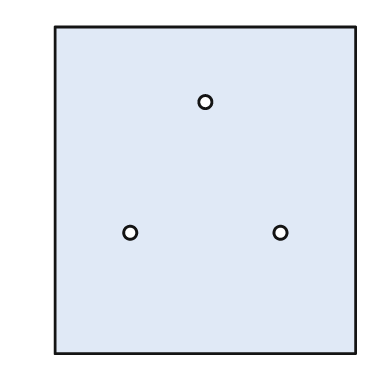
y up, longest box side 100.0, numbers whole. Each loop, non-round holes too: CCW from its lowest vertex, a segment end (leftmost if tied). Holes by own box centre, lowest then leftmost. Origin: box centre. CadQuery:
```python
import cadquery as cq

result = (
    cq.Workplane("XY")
    .moveTo(-46.0, -50.0)
    .lineTo(46.0, -50.0)
    .lineTo(46.0, 50.0)
    .lineTo(-46.0, 50.0)
    .close()
    .moveTo(-23.0, -13.0)
    .circle(2.0)
    .moveTo(23.0, -13.0)
    .circle(2.0)
    .moveTo(0.0, 27.0)
    .circle(2.0)
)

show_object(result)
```